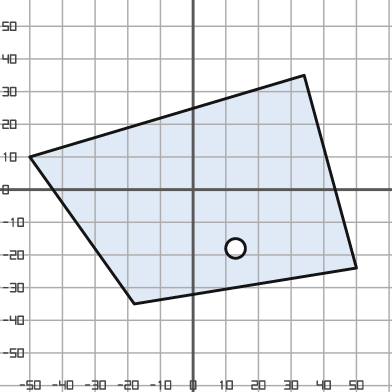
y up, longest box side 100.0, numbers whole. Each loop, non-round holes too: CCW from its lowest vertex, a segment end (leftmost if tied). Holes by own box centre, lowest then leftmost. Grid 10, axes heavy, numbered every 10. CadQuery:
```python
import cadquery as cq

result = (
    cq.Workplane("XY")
    .moveTo(-18.0, -35.0)
    .lineTo(50.0, -24.0)
    .lineTo(34.0, 35.0)
    .lineTo(-50.0, 10.0)
    .close()
    .moveTo(13.0, -18.0)
    .circle(3.0)
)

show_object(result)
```